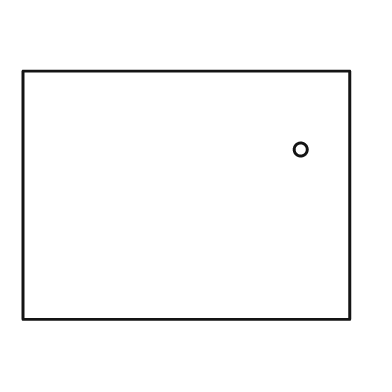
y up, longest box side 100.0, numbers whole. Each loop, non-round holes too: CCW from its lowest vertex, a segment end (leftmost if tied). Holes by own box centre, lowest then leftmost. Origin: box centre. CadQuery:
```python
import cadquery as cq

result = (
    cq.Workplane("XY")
    .moveTo(-50.0, -38.0)
    .lineTo(50.0, -38.0)
    .lineTo(50.0, 38.0)
    .lineTo(-50.0, 38.0)
    .close()
    .moveTo(35.0, 14.0)
    .circle(2.0)
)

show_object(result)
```